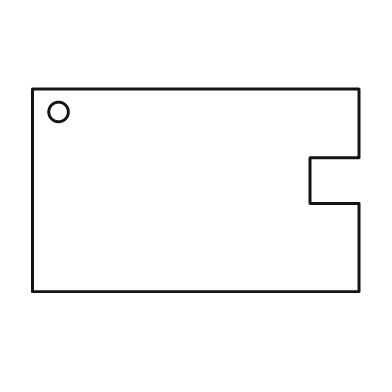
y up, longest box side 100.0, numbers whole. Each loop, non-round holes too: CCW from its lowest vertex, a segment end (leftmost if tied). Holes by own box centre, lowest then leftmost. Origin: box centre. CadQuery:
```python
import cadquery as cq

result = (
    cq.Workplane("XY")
    .moveTo(-50.0, -31.0)
    .lineTo(50.0, -31.0)
    .lineTo(50.0, -4.0)
    .lineTo(35.0, -4.0)
    .lineTo(35.0, 10.0)
    .lineTo(50.0, 10.0)
    .lineTo(50.0, 31.0)
    .lineTo(-50.0, 31.0)
    .close()
    .moveTo(-42.0, 24.0)
    .circle(3.0)
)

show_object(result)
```